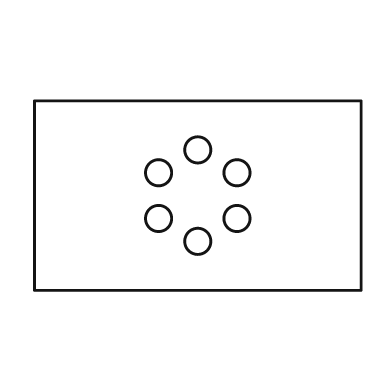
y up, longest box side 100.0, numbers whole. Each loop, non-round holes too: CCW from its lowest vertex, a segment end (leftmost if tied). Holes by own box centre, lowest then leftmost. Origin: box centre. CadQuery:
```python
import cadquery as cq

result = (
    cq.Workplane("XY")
    .moveTo(-50.0, -29.0)
    .lineTo(50.0, -29.0)
    .lineTo(50.0, 29.0)
    .lineTo(-50.0, 29.0)
    .close()
    .moveTo(0.0, -14.0)
    .circle(4.0)
    .moveTo(-12.0, -7.0)
    .circle(4.0)
    .moveTo(12.0, -7.0)
    .circle(4.0)
    .moveTo(-12.0, 7.0)
    .circle(4.0)
    .moveTo(12.0, 7.0)
    .circle(4.0)
    .moveTo(0.0, 14.0)
    .circle(4.0)
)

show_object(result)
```